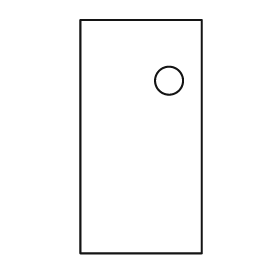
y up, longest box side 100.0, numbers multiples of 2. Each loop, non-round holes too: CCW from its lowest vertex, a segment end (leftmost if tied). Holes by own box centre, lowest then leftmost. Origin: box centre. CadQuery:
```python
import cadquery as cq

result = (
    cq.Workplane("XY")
    .moveTo(-26.0, -50.0)
    .lineTo(26.0, -50.0)
    .lineTo(26.0, 50.0)
    .lineTo(-26.0, 50.0)
    .close()
    .moveTo(12.0, 24.0)
    .circle(6.0)
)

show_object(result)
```